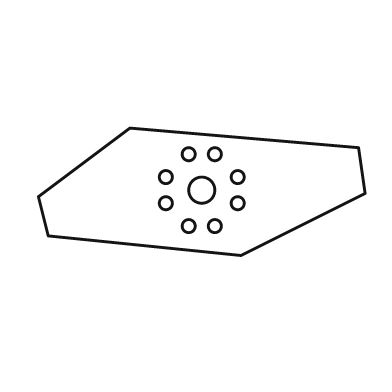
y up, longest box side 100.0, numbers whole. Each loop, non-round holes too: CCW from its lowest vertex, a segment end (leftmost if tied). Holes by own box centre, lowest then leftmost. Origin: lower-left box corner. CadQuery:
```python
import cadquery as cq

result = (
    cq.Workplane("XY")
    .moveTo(62.0, 0.0)
    .lineTo(100.0, 19.0)
    .lineTo(98.0, 33.0)
    .lineTo(28.0, 39.0)
    .lineTo(0.0, 18.0)
    .lineTo(3.0, 6.0)
    .close()
    .moveTo(46.0, 9.0)
    .circle(2.0)
    .moveTo(54.0, 9.0)
    .circle(2.0)
    .moveTo(39.0, 16.0)
    .circle(2.0)
    .moveTo(61.0, 16.0)
    .circle(2.0)
    .moveTo(50.0, 20.0)
    .circle(4.0)
    .moveTo(39.0, 24.0)
    .circle(2.0)
    .moveTo(61.0, 24.0)
    .circle(2.0)
    .moveTo(46.0, 31.0)
    .circle(2.0)
    .moveTo(54.0, 31.0)
    .circle(2.0)
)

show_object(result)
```